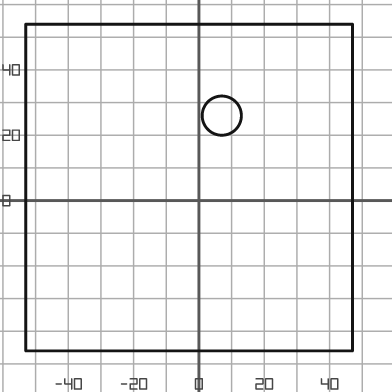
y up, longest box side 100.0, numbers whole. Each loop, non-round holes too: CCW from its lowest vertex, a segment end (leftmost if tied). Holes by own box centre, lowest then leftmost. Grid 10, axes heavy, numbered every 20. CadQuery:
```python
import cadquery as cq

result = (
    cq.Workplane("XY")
    .moveTo(-53.0, -46.0)
    .lineTo(47.0, -46.0)
    .lineTo(47.0, 54.0)
    .lineTo(-53.0, 54.0)
    .close()
    .moveTo(7.0, 26.0)
    .circle(6.0)
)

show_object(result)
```